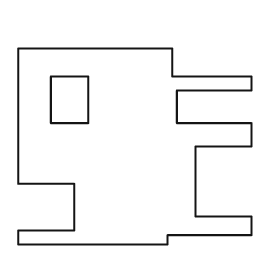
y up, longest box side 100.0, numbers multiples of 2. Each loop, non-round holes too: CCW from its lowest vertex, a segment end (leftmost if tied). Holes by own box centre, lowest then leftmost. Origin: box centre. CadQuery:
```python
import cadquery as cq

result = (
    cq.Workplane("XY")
    .moveTo(-50.0, -42.0)
    .lineTo(14.0, -42.0)
    .lineTo(14.0, -38.0)
    .lineTo(50.0, -38.0)
    .lineTo(50.0, -30.0)
    .lineTo(26.0, -30.0)
    .lineTo(26.0, 0.0)
    .lineTo(50.0, 0.0)
    .lineTo(50.0, 10.0)
    .lineTo(18.0, 10.0)
    .lineTo(18.0, 24.0)
    .lineTo(50.0, 24.0)
    .lineTo(50.0, 30.0)
    .lineTo(16.0, 30.0)
    .lineTo(16.0, 42.0)
    .lineTo(-50.0, 42.0)
    .lineTo(-50.0, -16.0)
    .lineTo(-26.0, -16.0)
    .lineTo(-26.0, -36.0)
    .lineTo(-50.0, -36.0)
    .close()
    .moveTo(-36.0, 10.0)
    .lineTo(-20.0, 10.0)
    .lineTo(-20.0, 30.0)
    .lineTo(-36.0, 30.0)
    .close()
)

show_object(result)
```